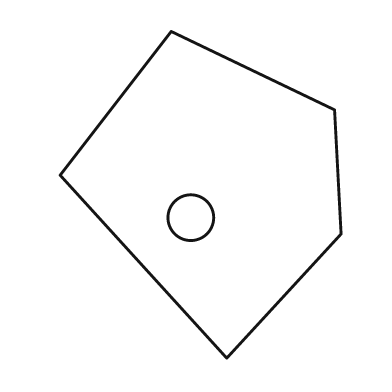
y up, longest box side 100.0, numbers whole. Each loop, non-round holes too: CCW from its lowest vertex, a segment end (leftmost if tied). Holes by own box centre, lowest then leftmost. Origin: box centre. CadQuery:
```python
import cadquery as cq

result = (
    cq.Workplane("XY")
    .moveTo(8.0, -50.0)
    .lineTo(43.0, -12.0)
    .lineTo(41.0, 26.0)
    .lineTo(-9.0, 50.0)
    .lineTo(-43.0, 6.0)
    .close()
    .moveTo(-3.0, -7.0)
    .circle(7.0)
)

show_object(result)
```